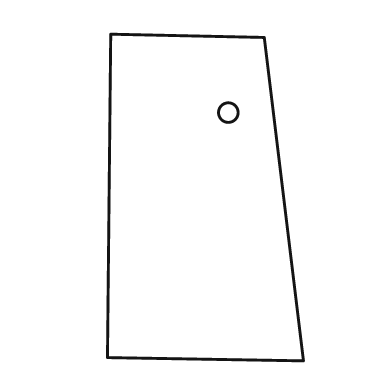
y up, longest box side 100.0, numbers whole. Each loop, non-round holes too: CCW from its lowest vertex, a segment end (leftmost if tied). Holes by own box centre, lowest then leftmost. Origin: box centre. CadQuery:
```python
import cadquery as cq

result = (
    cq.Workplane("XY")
    .moveTo(30.0, -50.0)
    .lineTo(18.0, 49.0)
    .lineTo(-29.0, 50.0)
    .lineTo(-30.0, -49.0)
    .close()
    .moveTo(7.0, 26.0)
    .circle(3.0)
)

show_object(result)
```